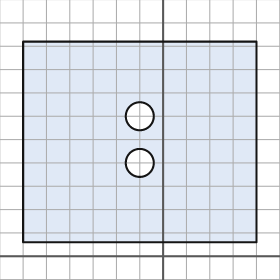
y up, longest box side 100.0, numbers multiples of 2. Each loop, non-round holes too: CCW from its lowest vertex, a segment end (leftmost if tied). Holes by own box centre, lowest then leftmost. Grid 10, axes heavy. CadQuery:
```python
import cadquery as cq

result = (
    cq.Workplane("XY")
    .moveTo(-60.0, 6.0)
    .lineTo(40.0, 6.0)
    .lineTo(40.0, 92.0)
    .lineTo(-60.0, 92.0)
    .close()
    .moveTo(-10.0, 40.0)
    .circle(6.0)
    .moveTo(-10.0, 60.0)
    .circle(6.0)
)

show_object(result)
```